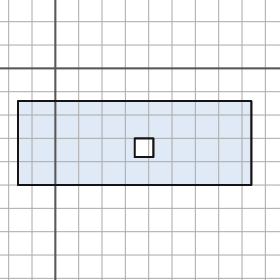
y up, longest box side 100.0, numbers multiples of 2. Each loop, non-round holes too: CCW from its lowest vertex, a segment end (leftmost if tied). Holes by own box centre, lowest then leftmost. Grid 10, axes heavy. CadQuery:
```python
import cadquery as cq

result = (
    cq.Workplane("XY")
    .moveTo(-16.0, -50.0)
    .lineTo(84.0, -50.0)
    .lineTo(84.0, -14.0)
    .lineTo(-16.0, -14.0)
    .close()
    .moveTo(34.0, -38.0)
    .lineTo(42.0, -38.0)
    .lineTo(42.0, -30.0)
    .lineTo(34.0, -30.0)
    .close()
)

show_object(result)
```